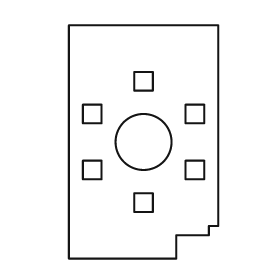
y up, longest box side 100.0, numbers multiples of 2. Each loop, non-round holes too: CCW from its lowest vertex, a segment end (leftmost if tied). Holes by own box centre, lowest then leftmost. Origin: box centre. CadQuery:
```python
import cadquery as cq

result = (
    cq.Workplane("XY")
    .moveTo(-32.0, -50.0)
    .lineTo(14.0, -50.0)
    .lineTo(14.0, -40.0)
    .lineTo(28.0, -40.0)
    .lineTo(28.0, -36.0)
    .lineTo(32.0, -36.0)
    .lineTo(32.0, 50.0)
    .lineTo(-32.0, 50.0)
    .close()
    .moveTo(-4.0, -30.0)
    .lineTo(4.0, -30.0)
    .lineTo(4.0, -22.0)
    .lineTo(-4.0, -22.0)
    .close()
    .moveTo(-26.0, -16.0)
    .lineTo(-18.0, -16.0)
    .lineTo(-18.0, -8.0)
    .lineTo(-26.0, -8.0)
    .close()
    .moveTo(18.0, -16.0)
    .lineTo(26.0, -16.0)
    .lineTo(26.0, -8.0)
    .lineTo(18.0, -8.0)
    .close()
    .moveTo(0.0, 0.0)
    .circle(12.0)
    .moveTo(-26.0, 8.0)
    .lineTo(-18.0, 8.0)
    .lineTo(-18.0, 16.0)
    .lineTo(-26.0, 16.0)
    .close()
    .moveTo(18.0, 8.0)
    .lineTo(26.0, 8.0)
    .lineTo(26.0, 16.0)
    .lineTo(18.0, 16.0)
    .close()
    .moveTo(-4.0, 22.0)
    .lineTo(4.0, 22.0)
    .lineTo(4.0, 30.0)
    .lineTo(-4.0, 30.0)
    .close()
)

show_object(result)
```